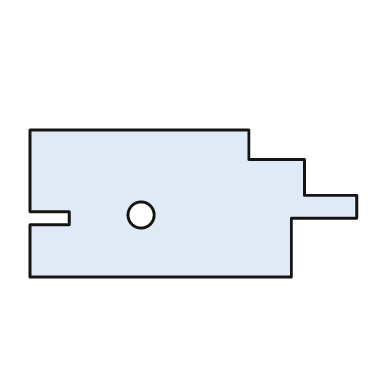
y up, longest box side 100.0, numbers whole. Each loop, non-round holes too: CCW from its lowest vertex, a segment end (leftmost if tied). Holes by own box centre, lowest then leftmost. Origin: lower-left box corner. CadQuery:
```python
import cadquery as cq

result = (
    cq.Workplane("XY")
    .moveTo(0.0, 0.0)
    .lineTo(80.0, 0.0)
    .lineTo(80.0, 18.0)
    .lineTo(100.0, 18.0)
    .lineTo(100.0, 25.0)
    .lineTo(84.0, 25.0)
    .lineTo(84.0, 36.0)
    .lineTo(67.0, 36.0)
    .lineTo(67.0, 45.0)
    .lineTo(0.0, 45.0)
    .lineTo(0.0, 20.0)
    .lineTo(12.0, 20.0)
    .lineTo(12.0, 16.0)
    .lineTo(0.0, 16.0)
    .close()
    .moveTo(34.0, 19.0)
    .circle(4.0)
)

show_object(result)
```